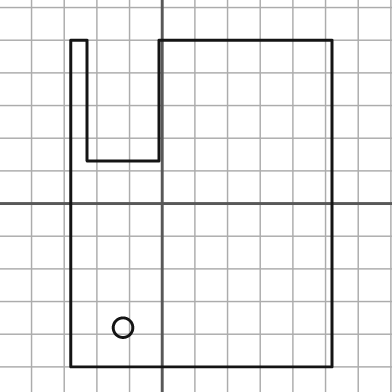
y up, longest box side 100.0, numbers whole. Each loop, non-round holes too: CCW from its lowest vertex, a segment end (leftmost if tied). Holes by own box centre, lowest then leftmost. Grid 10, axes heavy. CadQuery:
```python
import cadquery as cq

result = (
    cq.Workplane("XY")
    .moveTo(-28.0, -50.0)
    .lineTo(52.0, -50.0)
    .lineTo(52.0, 50.0)
    .lineTo(-1.0, 50.0)
    .lineTo(-1.0, 13.0)
    .lineTo(-23.0, 13.0)
    .lineTo(-23.0, 50.0)
    .lineTo(-28.0, 50.0)
    .close()
    .moveTo(-12.0, -38.0)
    .circle(3.0)
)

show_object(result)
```